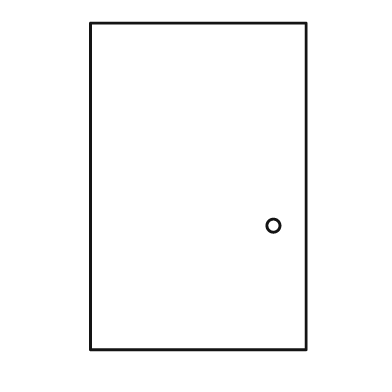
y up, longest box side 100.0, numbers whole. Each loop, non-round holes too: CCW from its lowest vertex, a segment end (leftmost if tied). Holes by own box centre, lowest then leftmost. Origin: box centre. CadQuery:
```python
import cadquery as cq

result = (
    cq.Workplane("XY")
    .moveTo(-33.0, -50.0)
    .lineTo(33.0, -50.0)
    .lineTo(33.0, 50.0)
    .lineTo(-33.0, 50.0)
    .close()
    .moveTo(23.0, -12.0)
    .circle(2.0)
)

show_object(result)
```